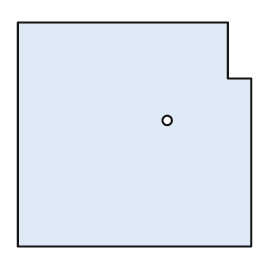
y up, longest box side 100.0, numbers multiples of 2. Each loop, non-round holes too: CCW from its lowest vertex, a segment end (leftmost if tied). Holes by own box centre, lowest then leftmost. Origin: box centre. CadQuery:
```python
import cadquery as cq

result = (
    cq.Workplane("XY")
    .moveTo(-50.0, -48.0)
    .lineTo(50.0, -48.0)
    .lineTo(50.0, 24.0)
    .lineTo(40.0, 24.0)
    .lineTo(40.0, 48.0)
    .lineTo(-50.0, 48.0)
    .close()
    .moveTo(14.0, 6.0)
    .circle(2.0)
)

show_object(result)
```